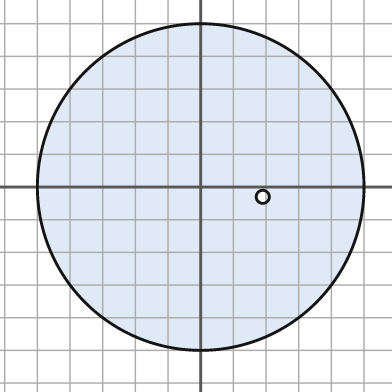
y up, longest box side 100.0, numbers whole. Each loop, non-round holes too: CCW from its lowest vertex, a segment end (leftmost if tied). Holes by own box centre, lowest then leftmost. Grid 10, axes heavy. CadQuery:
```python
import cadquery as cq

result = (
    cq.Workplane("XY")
    .moveTo(0.0, 0.0)
    .circle(50.0)
    .moveTo(19.0, -3.0)
    .circle(2.0)
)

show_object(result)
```